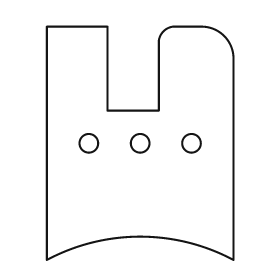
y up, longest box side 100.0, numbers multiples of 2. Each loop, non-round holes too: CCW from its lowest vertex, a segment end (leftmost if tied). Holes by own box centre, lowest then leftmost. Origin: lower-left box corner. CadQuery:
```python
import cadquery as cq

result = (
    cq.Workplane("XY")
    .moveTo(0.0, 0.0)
    .threePointArc((40.0, 10.0), (80.0, 0.0))
    .lineTo(80.0, 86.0)
    .threePointArc((76.0, 96.0), (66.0, 100.0))
    .lineTo(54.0, 100.0)
    .threePointArc((50.0, 98.0), (48.0, 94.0))
    .lineTo(48.0, 64.0)
    .lineTo(26.0, 64.0)
    .lineTo(26.0, 100.0)
    .lineTo(0.0, 100.0)
    .close()
    .moveTo(18.0, 50.0)
    .circle(4.0)
    .moveTo(40.0, 50.0)
    .circle(4.0)
    .moveTo(62.0, 50.0)
    .circle(4.0)
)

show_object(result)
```